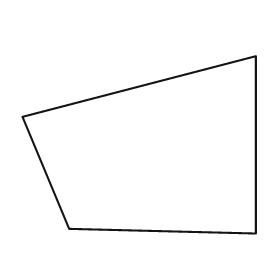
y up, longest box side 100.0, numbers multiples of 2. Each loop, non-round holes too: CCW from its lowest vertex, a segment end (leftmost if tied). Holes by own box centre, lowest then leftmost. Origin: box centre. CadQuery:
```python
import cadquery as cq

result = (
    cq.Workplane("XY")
    .moveTo(50.0, -38.0)
    .lineTo(50.0, 38.0)
    .lineTo(-50.0, 12.0)
    .lineTo(-30.0, -36.0)
    .close()
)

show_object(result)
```